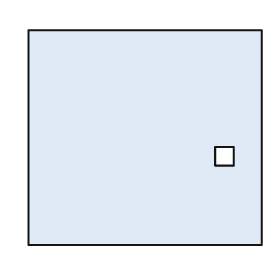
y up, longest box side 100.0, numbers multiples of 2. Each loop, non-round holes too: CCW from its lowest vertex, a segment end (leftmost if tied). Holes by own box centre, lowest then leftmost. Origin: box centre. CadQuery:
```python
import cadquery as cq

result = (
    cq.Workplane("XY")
    .moveTo(-50.0, -46.0)
    .lineTo(50.0, -46.0)
    .lineTo(50.0, 46.0)
    .lineTo(-50.0, 46.0)
    .close()
    .moveTo(30.0, -12.0)
    .lineTo(38.0, -12.0)
    .lineTo(38.0, -4.0)
    .lineTo(30.0, -4.0)
    .close()
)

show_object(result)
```